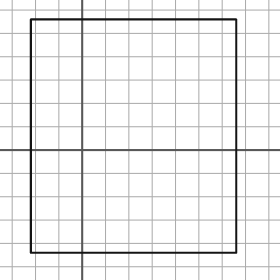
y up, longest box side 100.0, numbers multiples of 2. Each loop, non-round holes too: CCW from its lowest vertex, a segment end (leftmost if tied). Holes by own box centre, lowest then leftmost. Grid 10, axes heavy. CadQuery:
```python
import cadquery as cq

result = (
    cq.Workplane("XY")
    .moveTo(-22.0, -44.0)
    .lineTo(66.0, -44.0)
    .lineTo(66.0, 56.0)
    .lineTo(-22.0, 56.0)
    .close()
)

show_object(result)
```